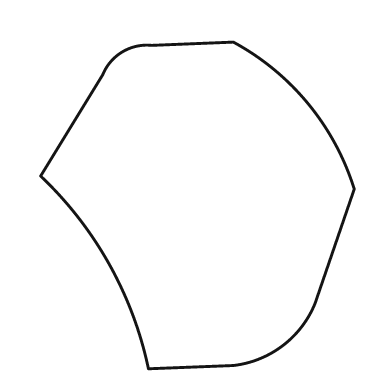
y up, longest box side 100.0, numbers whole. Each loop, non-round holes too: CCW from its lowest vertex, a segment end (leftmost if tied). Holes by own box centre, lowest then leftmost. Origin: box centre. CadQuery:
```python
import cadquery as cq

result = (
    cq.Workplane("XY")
    .moveTo(-15.0, -50.0)
    .lineTo(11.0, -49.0)
    .threePointArc((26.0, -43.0), (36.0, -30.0))
    .lineTo(48.0, 5.0)
    .threePointArc((34.0, 31.0), (11.0, 50.0))
    .lineTo(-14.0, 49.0)
    .threePointArc((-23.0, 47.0), (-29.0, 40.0))
    .lineTo(-48.0, 9.0)
    .threePointArc((-27.0, -18.0), (-15.0, -50.0))
    .close()
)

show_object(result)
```